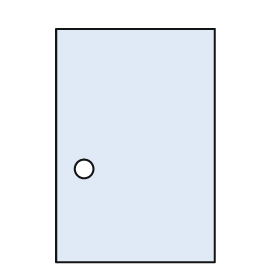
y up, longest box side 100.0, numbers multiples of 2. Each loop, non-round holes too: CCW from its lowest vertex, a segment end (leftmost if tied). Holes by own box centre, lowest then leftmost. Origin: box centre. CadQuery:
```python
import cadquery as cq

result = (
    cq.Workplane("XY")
    .moveTo(-34.0, -50.0)
    .lineTo(34.0, -50.0)
    .lineTo(34.0, 50.0)
    .lineTo(-34.0, 50.0)
    .close()
    .moveTo(-22.0, -10.0)
    .circle(4.0)
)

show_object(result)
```